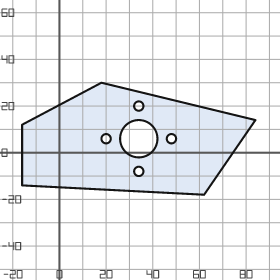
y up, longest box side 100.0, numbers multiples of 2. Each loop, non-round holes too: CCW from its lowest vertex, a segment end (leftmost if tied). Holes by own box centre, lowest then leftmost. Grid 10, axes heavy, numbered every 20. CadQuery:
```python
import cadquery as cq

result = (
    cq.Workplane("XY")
    .moveTo(62.0, -18.0)
    .lineTo(84.0, 14.0)
    .lineTo(18.0, 30.0)
    .lineTo(-16.0, 12.0)
    .lineTo(-16.0, -14.0)
    .close()
    .moveTo(34.0, -8.0)
    .circle(2.0)
    .moveTo(20.0, 6.0)
    .circle(2.0)
    .moveTo(34.0, 6.0)
    .circle(8.0)
    .moveTo(48.0, 6.0)
    .circle(2.0)
    .moveTo(34.0, 20.0)
    .circle(2.0)
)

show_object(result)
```